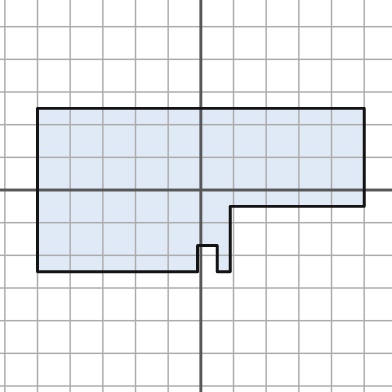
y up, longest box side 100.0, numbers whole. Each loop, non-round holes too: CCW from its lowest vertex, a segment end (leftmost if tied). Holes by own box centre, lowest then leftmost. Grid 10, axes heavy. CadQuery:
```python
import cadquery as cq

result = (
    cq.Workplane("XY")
    .moveTo(-50.0, -25.0)
    .lineTo(-1.0, -25.0)
    .lineTo(-1.0, -17.0)
    .lineTo(5.0, -17.0)
    .lineTo(5.0, -25.0)
    .lineTo(9.0, -25.0)
    .lineTo(9.0, -5.0)
    .lineTo(50.0, -5.0)
    .lineTo(50.0, 25.0)
    .lineTo(-50.0, 25.0)
    .close()
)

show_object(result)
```